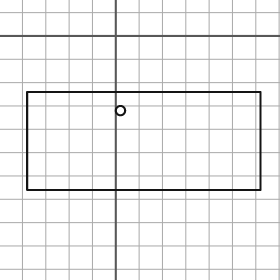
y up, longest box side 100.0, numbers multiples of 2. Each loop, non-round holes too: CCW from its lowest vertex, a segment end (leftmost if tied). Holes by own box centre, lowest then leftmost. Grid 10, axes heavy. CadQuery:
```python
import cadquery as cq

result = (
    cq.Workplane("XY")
    .moveTo(-38.0, -66.0)
    .lineTo(62.0, -66.0)
    .lineTo(62.0, -24.0)
    .lineTo(-38.0, -24.0)
    .close()
    .moveTo(2.0, -32.0)
    .circle(2.0)
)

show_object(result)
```